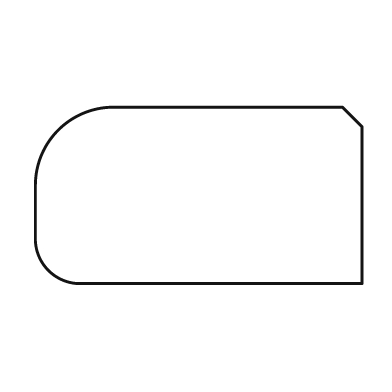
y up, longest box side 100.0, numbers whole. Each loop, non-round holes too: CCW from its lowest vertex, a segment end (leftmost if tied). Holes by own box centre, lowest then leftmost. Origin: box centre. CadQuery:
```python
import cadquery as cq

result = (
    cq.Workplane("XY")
    .moveTo(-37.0, -27.0)
    .lineTo(50.0, -27.0)
    .lineTo(50.0, 21.0)
    .lineTo(44.0, 27.0)
    .lineTo(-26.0, 27.0)
    .threePointArc((-43.0, 20.0), (-50.0, 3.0))
    .lineTo(-50.0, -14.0)
    .threePointArc((-46.0, -23.0), (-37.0, -27.0))
    .close()
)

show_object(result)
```